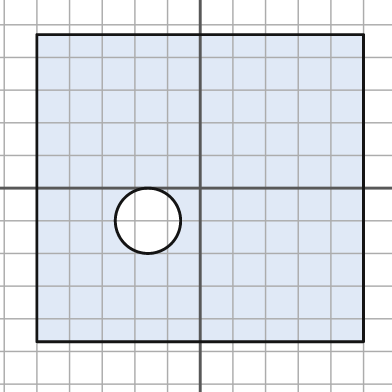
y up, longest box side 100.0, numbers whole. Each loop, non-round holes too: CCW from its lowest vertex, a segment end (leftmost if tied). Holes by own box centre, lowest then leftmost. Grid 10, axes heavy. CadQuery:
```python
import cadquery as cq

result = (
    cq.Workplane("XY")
    .moveTo(-50.0, -47.0)
    .lineTo(50.0, -47.0)
    .lineTo(50.0, 47.0)
    .lineTo(-50.0, 47.0)
    .close()
    .moveTo(-16.0, -10.0)
    .circle(10.0)
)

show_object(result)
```